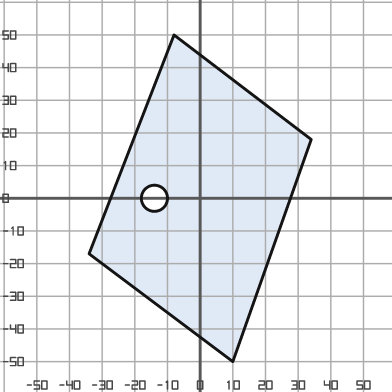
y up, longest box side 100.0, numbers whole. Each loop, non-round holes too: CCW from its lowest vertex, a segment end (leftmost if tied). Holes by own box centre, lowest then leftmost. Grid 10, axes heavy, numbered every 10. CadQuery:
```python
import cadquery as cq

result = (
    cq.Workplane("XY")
    .moveTo(10.0, -50.0)
    .lineTo(34.0, 18.0)
    .lineTo(-8.0, 50.0)
    .lineTo(-34.0, -17.0)
    .close()
    .moveTo(-14.0, 0.0)
    .circle(4.0)
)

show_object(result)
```